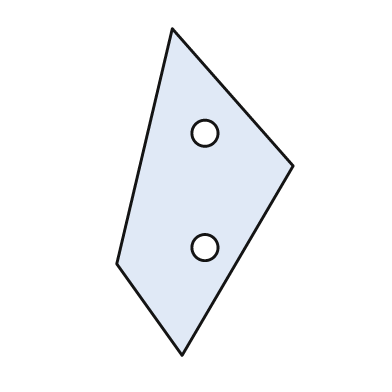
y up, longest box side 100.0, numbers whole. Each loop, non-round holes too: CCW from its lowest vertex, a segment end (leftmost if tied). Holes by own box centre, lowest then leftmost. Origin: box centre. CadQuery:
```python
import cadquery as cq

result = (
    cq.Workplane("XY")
    .moveTo(-7.0, -50.0)
    .lineTo(27.0, 8.0)
    .lineTo(-10.0, 50.0)
    .lineTo(-27.0, -22.0)
    .close()
    .moveTo(0.0, -17.0)
    .circle(4.0)
    .moveTo(0.0, 18.0)
    .circle(4.0)
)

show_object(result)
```